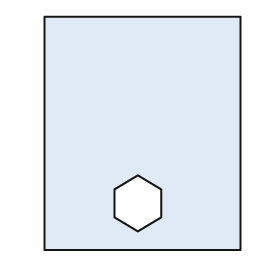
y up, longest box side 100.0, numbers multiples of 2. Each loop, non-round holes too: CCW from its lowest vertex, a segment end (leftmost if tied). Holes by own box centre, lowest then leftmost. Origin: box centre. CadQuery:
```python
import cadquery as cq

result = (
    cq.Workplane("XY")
    .moveTo(-42.0, -50.0)
    .lineTo(42.0, -50.0)
    .lineTo(42.0, 50.0)
    .lineTo(-42.0, 50.0)
    .close()
    .moveTo(-2.0, -42.0)
    .lineTo(8.0, -36.0)
    .lineTo(8.0, -24.0)
    .lineTo(-2.0, -18.0)
    .lineTo(-12.0, -24.0)
    .lineTo(-12.0, -36.0)
    .close()
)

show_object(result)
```